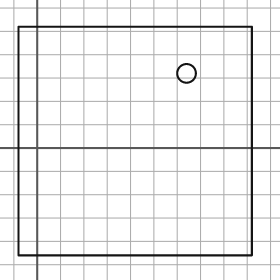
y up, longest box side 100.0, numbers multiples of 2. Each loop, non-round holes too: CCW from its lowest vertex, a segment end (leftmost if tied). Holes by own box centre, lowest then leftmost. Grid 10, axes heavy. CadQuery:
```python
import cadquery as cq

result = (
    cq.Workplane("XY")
    .moveTo(-8.0, -46.0)
    .lineTo(92.0, -46.0)
    .lineTo(92.0, 52.0)
    .lineTo(-8.0, 52.0)
    .close()
    .moveTo(64.0, 32.0)
    .circle(4.0)
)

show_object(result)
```